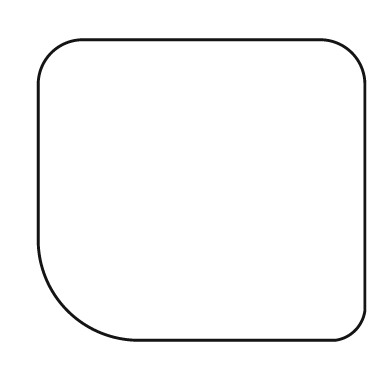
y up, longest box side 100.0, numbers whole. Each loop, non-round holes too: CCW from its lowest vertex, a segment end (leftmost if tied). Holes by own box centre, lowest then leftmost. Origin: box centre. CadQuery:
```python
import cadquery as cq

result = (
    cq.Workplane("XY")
    .moveTo(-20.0, -46.0)
    .lineTo(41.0, -46.0)
    .threePointArc((47.0, -43.0), (50.0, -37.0))
    .lineTo(50.0, 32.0)
    .threePointArc((46.0, 42.0), (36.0, 46.0))
    .lineTo(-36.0, 46.0)
    .threePointArc((-46.0, 42.0), (-50.0, 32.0))
    .lineTo(-50.0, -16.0)
    .threePointArc((-41.0, -37.0), (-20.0, -46.0))
    .close()
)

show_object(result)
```